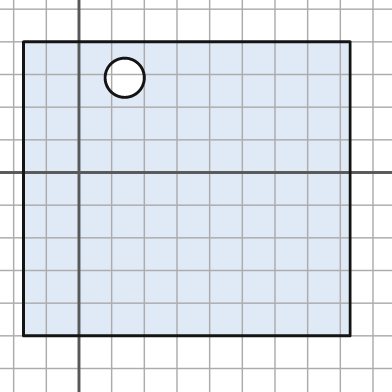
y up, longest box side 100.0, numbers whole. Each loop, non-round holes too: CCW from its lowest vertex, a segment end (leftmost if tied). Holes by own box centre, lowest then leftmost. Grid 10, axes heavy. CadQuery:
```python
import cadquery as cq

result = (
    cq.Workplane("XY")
    .moveTo(-17.0, -50.0)
    .lineTo(83.0, -50.0)
    .lineTo(83.0, 40.0)
    .lineTo(-17.0, 40.0)
    .close()
    .moveTo(14.0, 29.0)
    .circle(6.0)
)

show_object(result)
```